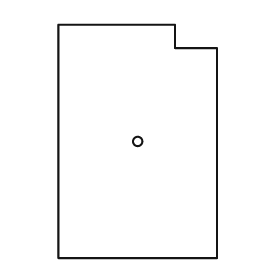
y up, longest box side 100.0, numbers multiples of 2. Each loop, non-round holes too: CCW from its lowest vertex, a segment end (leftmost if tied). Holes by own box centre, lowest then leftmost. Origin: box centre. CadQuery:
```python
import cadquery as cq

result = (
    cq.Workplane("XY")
    .moveTo(-34.0, -50.0)
    .lineTo(34.0, -50.0)
    .lineTo(34.0, 40.0)
    .lineTo(16.0, 40.0)
    .lineTo(16.0, 50.0)
    .lineTo(-34.0, 50.0)
    .close()
    .moveTo(0.0, 0.0)
    .circle(2.0)
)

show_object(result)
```